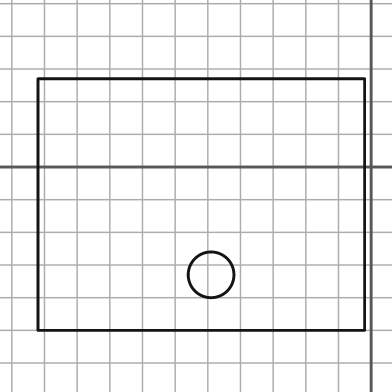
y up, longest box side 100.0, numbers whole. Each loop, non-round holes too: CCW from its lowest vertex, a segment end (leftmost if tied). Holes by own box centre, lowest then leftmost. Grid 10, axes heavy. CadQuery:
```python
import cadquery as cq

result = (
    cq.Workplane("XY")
    .moveTo(-102.0, -50.0)
    .lineTo(-2.0, -50.0)
    .lineTo(-2.0, 27.0)
    .lineTo(-102.0, 27.0)
    .close()
    .moveTo(-49.0, -33.0)
    .circle(7.0)
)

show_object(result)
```